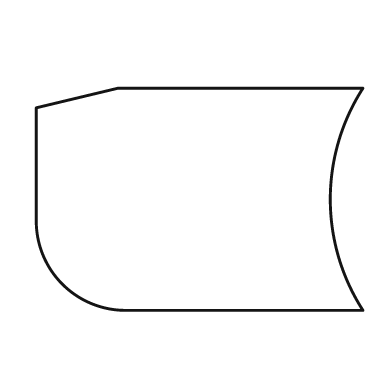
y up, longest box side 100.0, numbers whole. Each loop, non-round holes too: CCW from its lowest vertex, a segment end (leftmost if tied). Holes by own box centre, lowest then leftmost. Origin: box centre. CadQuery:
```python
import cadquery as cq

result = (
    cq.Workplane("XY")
    .moveTo(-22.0, -34.0)
    .lineTo(50.0, -34.0)
    .threePointArc((40.0, 0.0), (50.0, 34.0))
    .lineTo(-25.0, 34.0)
    .lineTo(-50.0, 28.0)
    .lineTo(-50.0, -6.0)
    .threePointArc((-42.0, -26.0), (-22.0, -34.0))
    .close()
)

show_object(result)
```